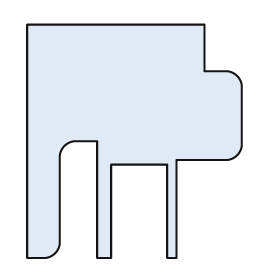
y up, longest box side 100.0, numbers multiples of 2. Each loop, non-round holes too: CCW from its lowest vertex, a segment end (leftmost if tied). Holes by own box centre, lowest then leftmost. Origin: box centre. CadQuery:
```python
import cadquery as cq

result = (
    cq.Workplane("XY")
    .moveTo(-46.0, -50.0)
    .lineTo(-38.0, -50.0)
    .threePointArc((-34.0, -48.0), (-32.0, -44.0))
    .lineTo(-32.0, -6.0)
    .threePointArc((-30.0, -2.0), (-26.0, 0.0))
    .lineTo(-16.0, 0.0)
    .lineTo(-16.0, -50.0)
    .lineTo(-10.0, -50.0)
    .lineTo(-10.0, -10.0)
    .lineTo(14.0, -10.0)
    .lineTo(14.0, -50.0)
    .lineTo(18.0, -50.0)
    .lineTo(18.0, -8.0)
    .lineTo(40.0, -8.0)
    .threePointArc((44.0, -6.0), (46.0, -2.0))
    .lineTo(46.0, 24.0)
    .threePointArc((44.0, 28.0), (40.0, 30.0))
    .lineTo(30.0, 30.0)
    .lineTo(30.0, 50.0)
    .lineTo(-46.0, 50.0)
    .close()
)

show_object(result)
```